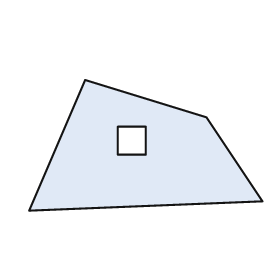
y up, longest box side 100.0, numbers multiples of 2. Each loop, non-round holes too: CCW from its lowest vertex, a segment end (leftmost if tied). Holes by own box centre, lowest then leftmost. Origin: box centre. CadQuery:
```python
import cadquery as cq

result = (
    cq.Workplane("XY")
    .moveTo(-50.0, -28.0)
    .lineTo(50.0, -24.0)
    .lineTo(26.0, 12.0)
    .lineTo(-26.0, 28.0)
    .close()
    .moveTo(-12.0, -4.0)
    .lineTo(0.0, -4.0)
    .lineTo(0.0, 8.0)
    .lineTo(-12.0, 8.0)
    .close()
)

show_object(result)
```